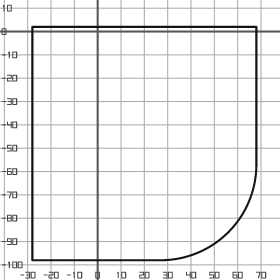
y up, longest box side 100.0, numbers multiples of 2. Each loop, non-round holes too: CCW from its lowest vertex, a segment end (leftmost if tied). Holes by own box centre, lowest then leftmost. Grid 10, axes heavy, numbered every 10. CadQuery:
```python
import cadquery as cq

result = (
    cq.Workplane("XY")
    .moveTo(-28.0, -98.0)
    .lineTo(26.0, -98.0)
    .threePointArc((56.0, -86.0), (68.0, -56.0))
    .lineTo(68.0, 2.0)
    .lineTo(-28.0, 2.0)
    .close()
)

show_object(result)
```